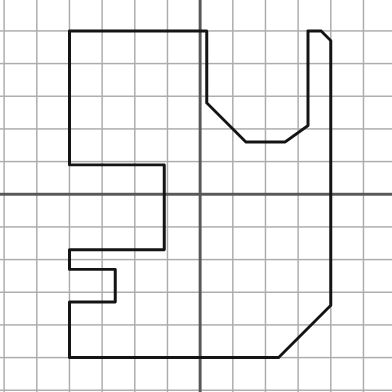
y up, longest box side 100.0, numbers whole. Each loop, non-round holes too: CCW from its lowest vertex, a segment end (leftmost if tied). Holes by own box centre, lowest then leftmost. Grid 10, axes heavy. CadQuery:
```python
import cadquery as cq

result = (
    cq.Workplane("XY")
    .moveTo(-40.0, -50.0)
    .lineTo(24.0, -50.0)
    .lineTo(40.0, -34.0)
    .lineTo(40.0, 47.0)
    .lineTo(37.0, 50.0)
    .lineTo(33.0, 50.0)
    .lineTo(33.0, 21.0)
    .lineTo(26.0, 16.0)
    .lineTo(14.0, 16.0)
    .lineTo(2.0, 28.0)
    .lineTo(2.0, 50.0)
    .lineTo(-40.0, 50.0)
    .lineTo(-40.0, 9.0)
    .lineTo(-11.0, 9.0)
    .lineTo(-11.0, -17.0)
    .lineTo(-40.0, -17.0)
    .lineTo(-40.0, -23.0)
    .lineTo(-26.0, -23.0)
    .lineTo(-26.0, -33.0)
    .lineTo(-40.0, -33.0)
    .close()
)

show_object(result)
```